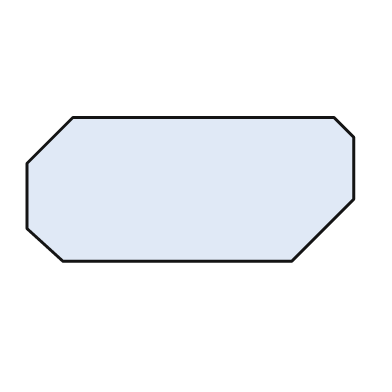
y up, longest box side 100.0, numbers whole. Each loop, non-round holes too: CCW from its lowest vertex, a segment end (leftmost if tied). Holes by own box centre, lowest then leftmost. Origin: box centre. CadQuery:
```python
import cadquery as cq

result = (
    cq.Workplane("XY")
    .moveTo(-39.0, -22.0)
    .lineTo(31.0, -22.0)
    .lineTo(50.0, -3.0)
    .lineTo(50.0, 16.0)
    .lineTo(44.0, 22.0)
    .lineTo(-36.0, 22.0)
    .lineTo(-50.0, 8.0)
    .lineTo(-50.0, -12.0)
    .close()
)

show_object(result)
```